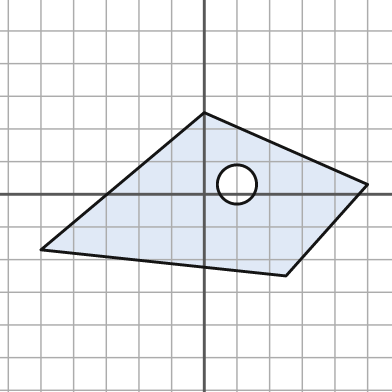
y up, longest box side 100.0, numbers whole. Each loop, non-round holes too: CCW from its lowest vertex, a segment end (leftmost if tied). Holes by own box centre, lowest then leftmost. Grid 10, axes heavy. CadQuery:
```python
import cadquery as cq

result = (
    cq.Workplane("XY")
    .moveTo(25.0, -25.0)
    .lineTo(50.0, 3.0)
    .lineTo(0.0, 25.0)
    .lineTo(-50.0, -17.0)
    .close()
    .moveTo(10.0, 3.0)
    .circle(6.0)
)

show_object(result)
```